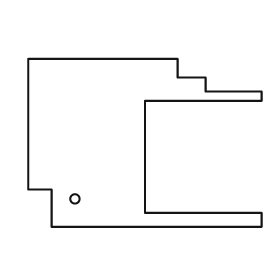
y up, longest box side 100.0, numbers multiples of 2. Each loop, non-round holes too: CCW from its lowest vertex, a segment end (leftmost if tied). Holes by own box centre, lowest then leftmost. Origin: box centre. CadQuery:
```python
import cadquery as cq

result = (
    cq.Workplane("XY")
    .moveTo(-40.0, -36.0)
    .lineTo(50.0, -36.0)
    .lineTo(50.0, -30.0)
    .lineTo(0.0, -30.0)
    .lineTo(0.0, 18.0)
    .lineTo(50.0, 18.0)
    .lineTo(50.0, 22.0)
    .lineTo(26.0, 22.0)
    .lineTo(26.0, 28.0)
    .lineTo(14.0, 28.0)
    .lineTo(14.0, 36.0)
    .lineTo(-50.0, 36.0)
    .lineTo(-50.0, -20.0)
    .lineTo(-40.0, -20.0)
    .close()
    .moveTo(-30.0, -24.0)
    .circle(2.0)
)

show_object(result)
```